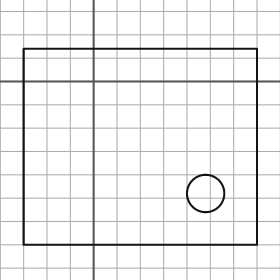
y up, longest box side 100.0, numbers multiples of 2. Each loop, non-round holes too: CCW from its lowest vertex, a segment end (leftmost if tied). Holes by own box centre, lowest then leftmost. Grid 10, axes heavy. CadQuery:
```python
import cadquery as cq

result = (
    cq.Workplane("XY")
    .moveTo(-30.0, -70.0)
    .lineTo(70.0, -70.0)
    .lineTo(70.0, 14.0)
    .lineTo(-30.0, 14.0)
    .close()
    .moveTo(48.0, -48.0)
    .circle(8.0)
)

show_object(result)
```